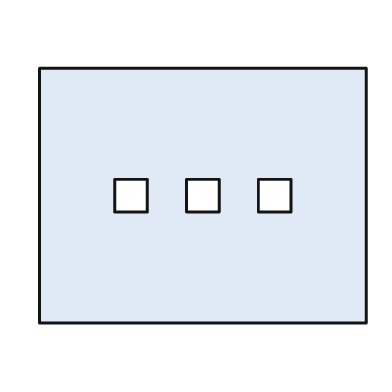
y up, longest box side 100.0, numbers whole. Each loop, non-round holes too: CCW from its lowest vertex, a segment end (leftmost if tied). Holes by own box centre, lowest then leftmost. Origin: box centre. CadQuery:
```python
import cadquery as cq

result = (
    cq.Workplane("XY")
    .moveTo(-50.0, -39.0)
    .lineTo(50.0, -39.0)
    .lineTo(50.0, 39.0)
    .lineTo(-50.0, 39.0)
    .close()
    .moveTo(-27.0, -5.0)
    .lineTo(-17.0, -5.0)
    .lineTo(-17.0, 5.0)
    .lineTo(-27.0, 5.0)
    .close()
    .moveTo(-5.0, -5.0)
    .lineTo(5.0, -5.0)
    .lineTo(5.0, 5.0)
    .lineTo(-5.0, 5.0)
    .close()
    .moveTo(17.0, -5.0)
    .lineTo(27.0, -5.0)
    .lineTo(27.0, 5.0)
    .lineTo(17.0, 5.0)
    .close()
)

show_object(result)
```